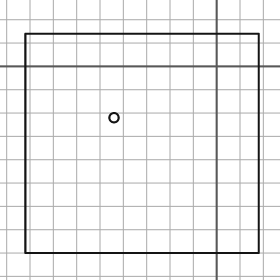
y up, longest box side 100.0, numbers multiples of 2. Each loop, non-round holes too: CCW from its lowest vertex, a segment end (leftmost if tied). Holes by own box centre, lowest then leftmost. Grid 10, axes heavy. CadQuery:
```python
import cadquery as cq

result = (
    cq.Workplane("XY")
    .moveTo(-82.0, -80.0)
    .lineTo(18.0, -80.0)
    .lineTo(18.0, 14.0)
    .lineTo(-82.0, 14.0)
    .close()
    .moveTo(-44.0, -22.0)
    .circle(2.0)
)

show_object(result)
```